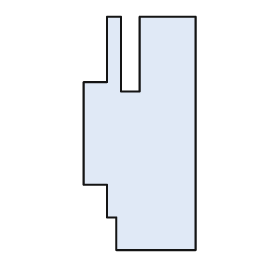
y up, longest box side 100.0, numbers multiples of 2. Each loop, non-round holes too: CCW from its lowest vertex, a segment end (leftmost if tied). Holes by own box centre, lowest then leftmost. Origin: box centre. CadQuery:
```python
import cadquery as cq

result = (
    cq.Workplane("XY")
    .moveTo(-10.0, -50.0)
    .lineTo(24.0, -50.0)
    .lineTo(24.0, 50.0)
    .lineTo(0.0, 50.0)
    .lineTo(0.0, 18.0)
    .lineTo(-8.0, 18.0)
    .lineTo(-8.0, 50.0)
    .lineTo(-14.0, 50.0)
    .lineTo(-14.0, 22.0)
    .lineTo(-24.0, 22.0)
    .lineTo(-24.0, -22.0)
    .lineTo(-14.0, -22.0)
    .lineTo(-14.0, -36.0)
    .lineTo(-10.0, -36.0)
    .close()
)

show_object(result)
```